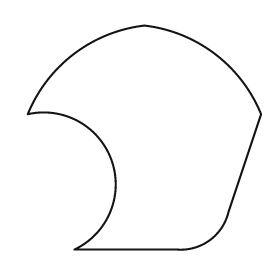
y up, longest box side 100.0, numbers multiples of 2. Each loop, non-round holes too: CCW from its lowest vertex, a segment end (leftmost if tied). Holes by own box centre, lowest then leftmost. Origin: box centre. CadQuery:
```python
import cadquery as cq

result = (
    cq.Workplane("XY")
    .moveTo(-30.0, -48.0)
    .lineTo(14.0, -48.0)
    .threePointArc((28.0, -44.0), (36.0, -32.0))
    .lineTo(50.0, 10.0)
    .threePointArc((30.0, 36.0), (0.0, 48.0))
    .threePointArc((-30.0, 36.0), (-50.0, 10.0))
    .threePointArc((-14.0, -10.0), (-30.0, -48.0))
    .close()
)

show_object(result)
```